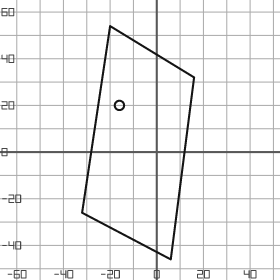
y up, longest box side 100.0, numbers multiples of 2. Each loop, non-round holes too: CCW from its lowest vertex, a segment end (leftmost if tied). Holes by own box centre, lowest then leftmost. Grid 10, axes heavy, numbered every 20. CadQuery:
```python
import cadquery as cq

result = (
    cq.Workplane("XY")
    .moveTo(6.0, -46.0)
    .lineTo(16.0, 32.0)
    .lineTo(-20.0, 54.0)
    .lineTo(-32.0, -26.0)
    .close()
    .moveTo(-16.0, 20.0)
    .circle(2.0)
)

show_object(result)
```